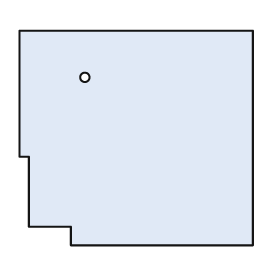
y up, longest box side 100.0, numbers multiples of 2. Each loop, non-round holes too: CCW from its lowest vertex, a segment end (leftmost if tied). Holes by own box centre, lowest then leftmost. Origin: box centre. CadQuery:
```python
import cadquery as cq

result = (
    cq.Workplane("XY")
    .moveTo(-28.0, -46.0)
    .lineTo(50.0, -46.0)
    .lineTo(50.0, 46.0)
    .lineTo(-50.0, 46.0)
    .lineTo(-50.0, -8.0)
    .lineTo(-46.0, -8.0)
    .lineTo(-46.0, -38.0)
    .lineTo(-28.0, -38.0)
    .close()
    .moveTo(-22.0, 26.0)
    .circle(2.0)
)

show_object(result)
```